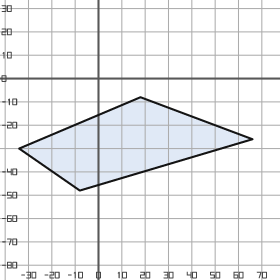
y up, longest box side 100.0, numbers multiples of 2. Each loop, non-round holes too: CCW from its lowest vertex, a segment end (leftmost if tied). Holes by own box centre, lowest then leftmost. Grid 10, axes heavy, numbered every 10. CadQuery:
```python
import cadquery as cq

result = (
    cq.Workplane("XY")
    .moveTo(-8.0, -48.0)
    .lineTo(66.0, -26.0)
    .lineTo(18.0, -8.0)
    .lineTo(-34.0, -30.0)
    .close()
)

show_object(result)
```